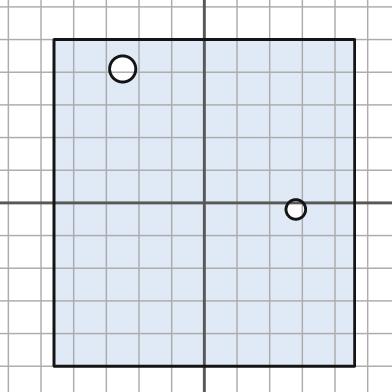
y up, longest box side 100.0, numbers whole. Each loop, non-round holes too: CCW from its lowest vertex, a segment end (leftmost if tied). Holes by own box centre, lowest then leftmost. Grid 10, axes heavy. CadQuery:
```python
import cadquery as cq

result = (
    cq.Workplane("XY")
    .moveTo(-46.0, -50.0)
    .lineTo(46.0, -50.0)
    .lineTo(46.0, 50.0)
    .lineTo(-46.0, 50.0)
    .close()
    .moveTo(28.0, -2.0)
    .circle(3.0)
    .moveTo(-25.0, 41.0)
    .circle(4.0)
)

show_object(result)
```